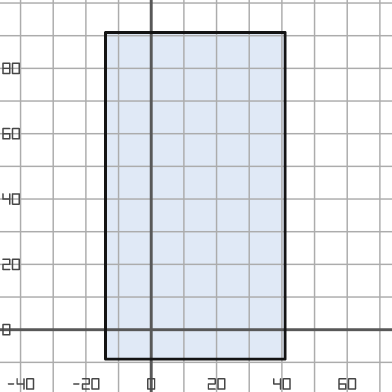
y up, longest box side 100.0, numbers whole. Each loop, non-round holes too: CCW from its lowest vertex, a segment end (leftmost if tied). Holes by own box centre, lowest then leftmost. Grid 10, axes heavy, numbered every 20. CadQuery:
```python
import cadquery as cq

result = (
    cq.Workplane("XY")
    .moveTo(-14.0, -9.0)
    .lineTo(41.0, -9.0)
    .lineTo(41.0, 91.0)
    .lineTo(-14.0, 91.0)
    .close()
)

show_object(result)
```